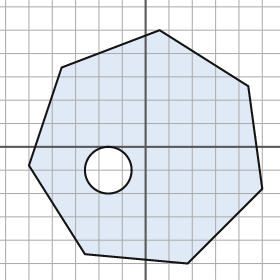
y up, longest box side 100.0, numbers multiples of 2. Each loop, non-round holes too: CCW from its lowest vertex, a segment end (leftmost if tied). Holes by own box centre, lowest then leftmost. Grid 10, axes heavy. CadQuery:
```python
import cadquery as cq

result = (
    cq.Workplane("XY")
    .moveTo(18.0, -50.0)
    .lineTo(50.0, -18.0)
    .lineTo(44.0, 26.0)
    .lineTo(6.0, 50.0)
    .lineTo(-36.0, 34.0)
    .lineTo(-50.0, -8.0)
    .lineTo(-26.0, -46.0)
    .close()
    .moveTo(-16.0, -10.0)
    .circle(10.0)
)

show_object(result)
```